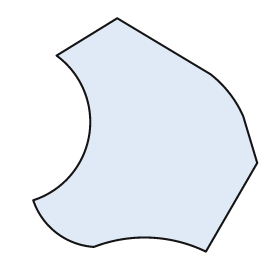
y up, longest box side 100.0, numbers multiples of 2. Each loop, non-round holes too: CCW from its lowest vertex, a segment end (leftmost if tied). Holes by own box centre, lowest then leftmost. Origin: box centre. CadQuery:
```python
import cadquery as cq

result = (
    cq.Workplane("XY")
    .moveTo(26.0, -50.0)
    .lineTo(48.0, -12.0)
    .lineTo(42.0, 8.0)
    .threePointArc((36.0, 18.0), (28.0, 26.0))
    .lineTo(-12.0, 50.0)
    .lineTo(-38.0, 34.0)
    .threePointArc((-24.0, 0.0), (-48.0, -28.0))
    .threePointArc((-38.0, -42.0), (-22.0, -48.0))
    .threePointArc((2.0, -44.0), (26.0, -50.0))
    .close()
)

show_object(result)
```